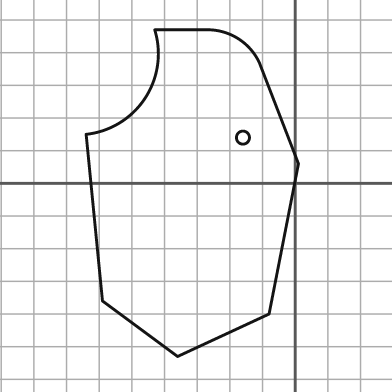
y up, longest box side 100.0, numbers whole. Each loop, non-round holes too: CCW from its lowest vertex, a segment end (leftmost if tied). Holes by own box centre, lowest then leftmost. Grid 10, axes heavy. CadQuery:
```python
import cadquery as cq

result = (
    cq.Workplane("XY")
    .moveTo(-36.0, -53.0)
    .lineTo(-8.0, -40.0)
    .lineTo(1.0, 6.0)
    .lineTo(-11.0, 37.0)
    .threePointArc((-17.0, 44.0), (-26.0, 47.0))
    .lineTo(-43.0, 47.0)
    .threePointArc((-46.0, 26.0), (-64.0, 15.0))
    .lineTo(-59.0, -36.0)
    .close()
    .moveTo(-16.0, 14.0)
    .circle(2.0)
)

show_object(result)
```